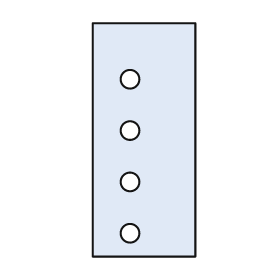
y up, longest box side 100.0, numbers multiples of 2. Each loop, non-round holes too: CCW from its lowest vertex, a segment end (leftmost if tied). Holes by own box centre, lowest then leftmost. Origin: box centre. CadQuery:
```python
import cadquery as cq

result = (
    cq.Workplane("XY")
    .moveTo(-22.0, -50.0)
    .lineTo(22.0, -50.0)
    .lineTo(22.0, 50.0)
    .lineTo(-22.0, 50.0)
    .close()
    .moveTo(-6.0, -40.0)
    .circle(4.0)
    .moveTo(-6.0, -18.0)
    .circle(4.0)
    .moveTo(-6.0, 4.0)
    .circle(4.0)
    .moveTo(-6.0, 26.0)
    .circle(4.0)
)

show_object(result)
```